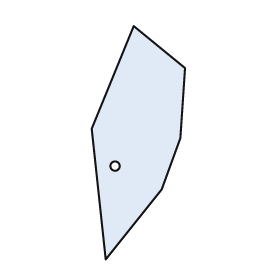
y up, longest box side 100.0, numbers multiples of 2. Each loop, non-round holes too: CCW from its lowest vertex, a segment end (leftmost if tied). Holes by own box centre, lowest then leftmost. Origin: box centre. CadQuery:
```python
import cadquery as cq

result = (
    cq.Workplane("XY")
    .moveTo(-14.0, -50.0)
    .lineTo(10.0, -20.0)
    .lineTo(18.0, 2.0)
    .lineTo(20.0, 32.0)
    .lineTo(-2.0, 50.0)
    .lineTo(-20.0, 6.0)
    .close()
    .moveTo(-10.0, -10.0)
    .circle(2.0)
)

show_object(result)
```